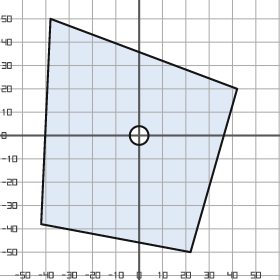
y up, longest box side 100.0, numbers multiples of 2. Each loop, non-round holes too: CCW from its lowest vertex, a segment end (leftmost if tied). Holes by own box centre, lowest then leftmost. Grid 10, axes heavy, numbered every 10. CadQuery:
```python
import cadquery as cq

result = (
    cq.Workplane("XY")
    .moveTo(22.0, -50.0)
    .lineTo(42.0, 20.0)
    .lineTo(-38.0, 50.0)
    .lineTo(-42.0, -38.0)
    .close()
    .moveTo(0.0, 0.0)
    .circle(4.0)
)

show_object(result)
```